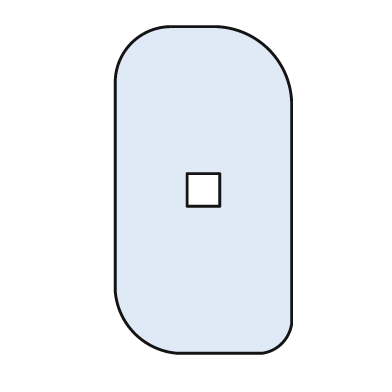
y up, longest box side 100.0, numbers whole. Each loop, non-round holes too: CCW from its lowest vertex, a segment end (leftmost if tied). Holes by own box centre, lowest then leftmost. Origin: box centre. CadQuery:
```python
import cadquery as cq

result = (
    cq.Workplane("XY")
    .moveTo(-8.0, -50.0)
    .lineTo(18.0, -50.0)
    .threePointArc((24.0, -47.0), (27.0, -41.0))
    .lineTo(27.0, 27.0)
    .threePointArc((20.0, 43.0), (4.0, 50.0))
    .lineTo(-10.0, 50.0)
    .threePointArc((-22.0, 45.0), (-27.0, 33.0))
    .lineTo(-27.0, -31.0)
    .threePointArc((-21.0, -44.0), (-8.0, -50.0))
    .close()
    .moveTo(-5.0, -5.0)
    .lineTo(5.0, -5.0)
    .lineTo(5.0, 5.0)
    .lineTo(-5.0, 5.0)
    .close()
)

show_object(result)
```